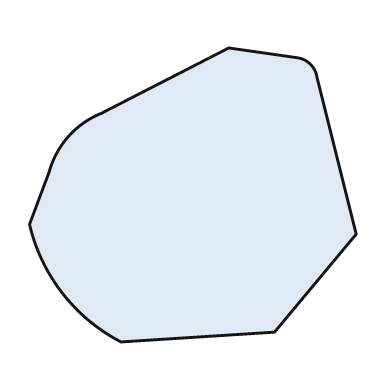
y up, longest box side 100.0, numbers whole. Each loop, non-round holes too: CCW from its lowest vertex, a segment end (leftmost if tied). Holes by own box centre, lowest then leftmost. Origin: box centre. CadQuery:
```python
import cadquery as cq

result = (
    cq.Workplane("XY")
    .moveTo(-22.0, -45.0)
    .lineTo(25.0, -42.0)
    .lineTo(50.0, -12.0)
    .lineTo(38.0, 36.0)
    .threePointArc((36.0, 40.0), (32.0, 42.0))
    .lineTo(11.0, 45.0)
    .lineTo(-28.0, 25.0)
    .threePointArc((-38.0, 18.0), (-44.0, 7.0))
    .lineTo(-50.0, -9.0)
    .threePointArc((-40.0, -30.0), (-22.0, -45.0))
    .close()
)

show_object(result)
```